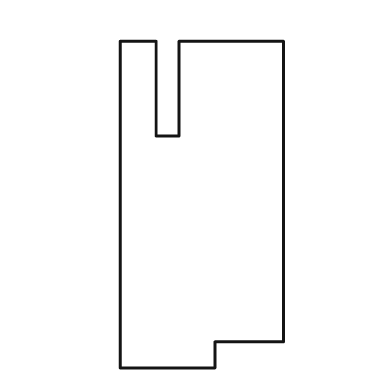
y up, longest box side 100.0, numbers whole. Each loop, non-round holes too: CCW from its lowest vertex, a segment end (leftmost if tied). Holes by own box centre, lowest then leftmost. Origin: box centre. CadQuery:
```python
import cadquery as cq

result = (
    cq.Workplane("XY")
    .moveTo(-25.0, -50.0)
    .lineTo(4.0, -50.0)
    .lineTo(4.0, -42.0)
    .lineTo(25.0, -42.0)
    .lineTo(25.0, 50.0)
    .lineTo(-7.0, 50.0)
    .lineTo(-7.0, 21.0)
    .lineTo(-14.0, 21.0)
    .lineTo(-14.0, 50.0)
    .lineTo(-25.0, 50.0)
    .close()
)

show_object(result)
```